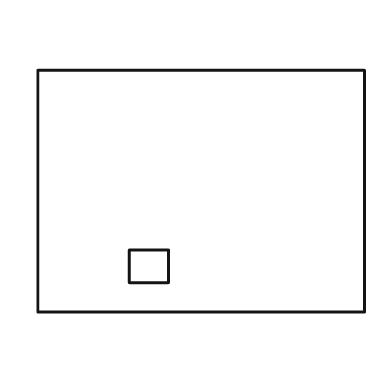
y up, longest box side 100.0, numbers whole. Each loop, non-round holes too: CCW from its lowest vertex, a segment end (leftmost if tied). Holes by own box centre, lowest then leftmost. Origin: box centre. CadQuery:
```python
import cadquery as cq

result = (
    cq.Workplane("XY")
    .moveTo(-50.0, -37.0)
    .lineTo(50.0, -37.0)
    .lineTo(50.0, 37.0)
    .lineTo(-50.0, 37.0)
    .close()
    .moveTo(-22.0, -28.0)
    .lineTo(-10.0, -28.0)
    .lineTo(-10.0, -18.0)
    .lineTo(-22.0, -18.0)
    .close()
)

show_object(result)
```